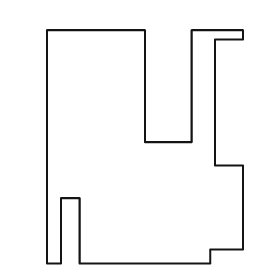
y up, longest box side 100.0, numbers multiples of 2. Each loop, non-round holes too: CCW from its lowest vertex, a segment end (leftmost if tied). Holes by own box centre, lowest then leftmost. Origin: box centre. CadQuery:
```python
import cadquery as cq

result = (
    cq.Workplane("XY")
    .moveTo(-42.0, -50.0)
    .lineTo(-36.0, -50.0)
    .lineTo(-36.0, -22.0)
    .lineTo(-28.0, -22.0)
    .lineTo(-28.0, -50.0)
    .lineTo(28.0, -50.0)
    .lineTo(28.0, -44.0)
    .lineTo(42.0, -44.0)
    .lineTo(42.0, -8.0)
    .lineTo(30.0, -8.0)
    .lineTo(30.0, 46.0)
    .lineTo(42.0, 46.0)
    .lineTo(42.0, 50.0)
    .lineTo(20.0, 50.0)
    .lineTo(20.0, 2.0)
    .lineTo(0.0, 2.0)
    .lineTo(0.0, 50.0)
    .lineTo(-42.0, 50.0)
    .close()
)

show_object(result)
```